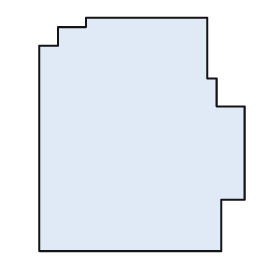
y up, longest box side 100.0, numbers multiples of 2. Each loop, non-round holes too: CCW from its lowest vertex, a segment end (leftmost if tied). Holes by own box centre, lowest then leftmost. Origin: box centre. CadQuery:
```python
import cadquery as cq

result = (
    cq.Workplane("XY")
    .moveTo(-44.0, -50.0)
    .lineTo(34.0, -50.0)
    .lineTo(34.0, -28.0)
    .lineTo(44.0, -28.0)
    .lineTo(44.0, 12.0)
    .lineTo(32.0, 12.0)
    .lineTo(32.0, 24.0)
    .lineTo(28.0, 24.0)
    .lineTo(28.0, 50.0)
    .lineTo(-24.0, 50.0)
    .lineTo(-24.0, 46.0)
    .lineTo(-36.0, 46.0)
    .lineTo(-36.0, 38.0)
    .lineTo(-44.0, 38.0)
    .close()
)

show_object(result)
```